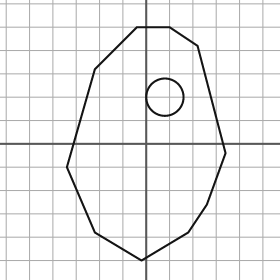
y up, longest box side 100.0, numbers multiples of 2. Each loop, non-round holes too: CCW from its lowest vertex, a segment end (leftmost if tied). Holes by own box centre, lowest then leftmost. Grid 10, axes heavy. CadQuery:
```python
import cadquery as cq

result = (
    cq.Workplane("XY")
    .moveTo(-2.0, -50.0)
    .lineTo(18.0, -38.0)
    .lineTo(26.0, -26.0)
    .lineTo(34.0, -4.0)
    .lineTo(22.0, 42.0)
    .lineTo(10.0, 50.0)
    .lineTo(-4.0, 50.0)
    .lineTo(-22.0, 32.0)
    .lineTo(-34.0, -10.0)
    .lineTo(-22.0, -38.0)
    .close()
    .moveTo(8.0, 20.0)
    .circle(8.0)
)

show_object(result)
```